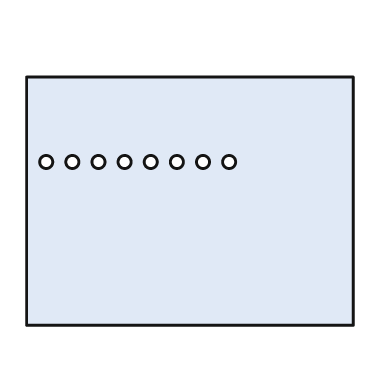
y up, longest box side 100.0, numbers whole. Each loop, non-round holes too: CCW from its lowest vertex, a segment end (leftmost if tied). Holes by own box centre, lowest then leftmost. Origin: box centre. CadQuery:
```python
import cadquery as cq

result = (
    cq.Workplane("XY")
    .moveTo(-50.0, -38.0)
    .lineTo(50.0, -38.0)
    .lineTo(50.0, 38.0)
    .lineTo(-50.0, 38.0)
    .close()
    .moveTo(-44.0, 12.0)
    .circle(2.0)
    .moveTo(-36.0, 12.0)
    .circle(2.0)
    .moveTo(-28.0, 12.0)
    .circle(2.0)
    .moveTo(-20.0, 12.0)
    .circle(2.0)
    .moveTo(-12.0, 12.0)
    .circle(2.0)
    .moveTo(-4.0, 12.0)
    .circle(2.0)
    .moveTo(4.0, 12.0)
    .circle(2.0)
    .moveTo(12.0, 12.0)
    .circle(2.0)
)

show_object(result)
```